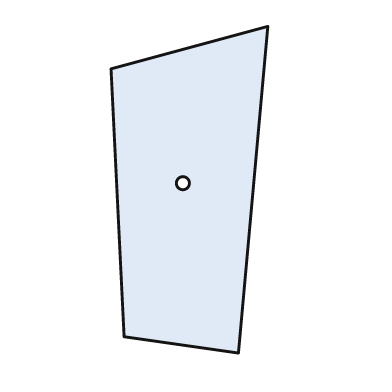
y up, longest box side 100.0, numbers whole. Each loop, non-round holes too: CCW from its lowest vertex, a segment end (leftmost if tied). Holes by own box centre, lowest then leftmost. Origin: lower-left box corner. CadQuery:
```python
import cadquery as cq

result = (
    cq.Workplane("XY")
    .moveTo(39.0, 0.0)
    .lineTo(48.0, 100.0)
    .lineTo(0.0, 87.0)
    .lineTo(4.0, 5.0)
    .close()
    .moveTo(22.0, 52.0)
    .circle(2.0)
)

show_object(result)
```